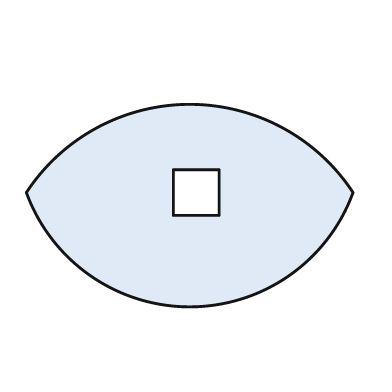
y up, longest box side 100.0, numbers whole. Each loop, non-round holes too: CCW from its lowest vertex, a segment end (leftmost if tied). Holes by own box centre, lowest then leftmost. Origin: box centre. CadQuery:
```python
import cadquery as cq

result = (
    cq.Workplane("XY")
    .moveTo(-50.0, 4.0)
    .threePointArc((0.0, -31.0), (50.0, 4.0))
    .threePointArc((0.0, 31.0), (-50.0, 4.0))
    .close()
    .moveTo(-5.0, -3.0)
    .lineTo(9.0, -3.0)
    .lineTo(9.0, 11.0)
    .lineTo(-5.0, 11.0)
    .close()
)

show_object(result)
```